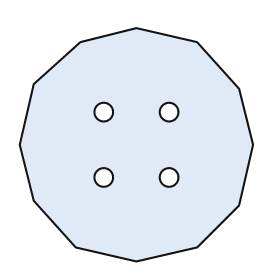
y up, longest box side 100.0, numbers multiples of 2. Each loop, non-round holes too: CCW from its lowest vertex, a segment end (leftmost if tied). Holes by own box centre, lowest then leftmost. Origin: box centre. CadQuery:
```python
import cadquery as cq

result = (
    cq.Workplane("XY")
    .moveTo(0.0, -50.0)
    .lineTo(26.0, -44.0)
    .lineTo(44.0, -26.0)
    .lineTo(50.0, 0.0)
    .lineTo(44.0, 24.0)
    .lineTo(26.0, 44.0)
    .lineTo(0.0, 50.0)
    .lineTo(-24.0, 44.0)
    .lineTo(-44.0, 26.0)
    .lineTo(-50.0, 0.0)
    .lineTo(-44.0, -24.0)
    .lineTo(-26.0, -44.0)
    .close()
    .moveTo(-14.0, -14.0)
    .circle(4.0)
    .moveTo(14.0, -14.0)
    .circle(4.0)
    .moveTo(-14.0, 14.0)
    .circle(4.0)
    .moveTo(14.0, 14.0)
    .circle(4.0)
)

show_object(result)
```